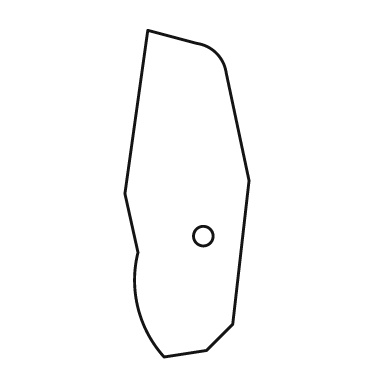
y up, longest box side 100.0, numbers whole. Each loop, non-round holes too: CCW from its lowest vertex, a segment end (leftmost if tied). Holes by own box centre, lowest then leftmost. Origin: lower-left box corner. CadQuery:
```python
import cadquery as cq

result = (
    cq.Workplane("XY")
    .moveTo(12.0, 0.0)
    .lineTo(25.0, 2.0)
    .lineTo(33.0, 10.0)
    .lineTo(38.0, 54.0)
    .lineTo(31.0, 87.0)
    .threePointArc((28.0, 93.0), (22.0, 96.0))
    .lineTo(7.0, 100.0)
    .lineTo(0.0, 50.0)
    .lineTo(4.0, 32.0)
    .threePointArc((4.0, 15.0), (12.0, 0.0))
    .close()
    .moveTo(24.0, 37.0)
    .circle(3.0)
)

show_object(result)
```